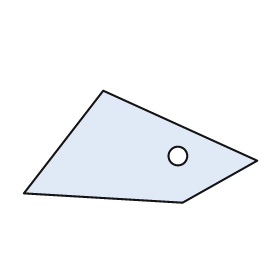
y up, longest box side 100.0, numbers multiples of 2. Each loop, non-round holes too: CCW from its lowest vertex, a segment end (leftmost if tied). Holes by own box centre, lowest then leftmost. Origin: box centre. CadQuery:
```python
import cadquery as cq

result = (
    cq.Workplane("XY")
    .moveTo(18.0, -24.0)
    .lineTo(50.0, -6.0)
    .lineTo(-16.0, 24.0)
    .lineTo(-50.0, -20.0)
    .close()
    .moveTo(16.0, -4.0)
    .circle(4.0)
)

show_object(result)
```